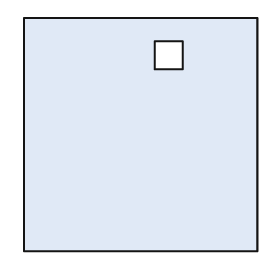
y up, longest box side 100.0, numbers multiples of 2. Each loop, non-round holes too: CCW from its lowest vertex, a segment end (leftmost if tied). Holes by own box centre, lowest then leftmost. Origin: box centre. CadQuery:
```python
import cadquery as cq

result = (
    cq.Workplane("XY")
    .moveTo(-50.0, -50.0)
    .lineTo(50.0, -50.0)
    .lineTo(50.0, 50.0)
    .lineTo(-50.0, 50.0)
    .close()
    .moveTo(6.0, 28.0)
    .lineTo(18.0, 28.0)
    .lineTo(18.0, 40.0)
    .lineTo(6.0, 40.0)
    .close()
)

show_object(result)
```